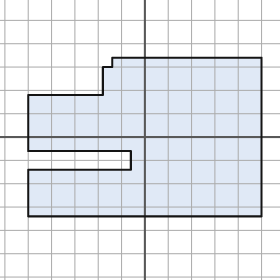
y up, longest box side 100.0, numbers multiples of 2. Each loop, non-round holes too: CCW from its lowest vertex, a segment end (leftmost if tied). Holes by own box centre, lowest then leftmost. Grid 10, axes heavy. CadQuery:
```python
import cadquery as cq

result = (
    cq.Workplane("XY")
    .moveTo(-50.0, -34.0)
    .lineTo(50.0, -34.0)
    .lineTo(50.0, 34.0)
    .lineTo(-14.0, 34.0)
    .lineTo(-14.0, 30.0)
    .lineTo(-18.0, 30.0)
    .lineTo(-18.0, 18.0)
    .lineTo(-50.0, 18.0)
    .lineTo(-50.0, -6.0)
    .lineTo(-6.0, -6.0)
    .lineTo(-6.0, -14.0)
    .lineTo(-50.0, -14.0)
    .close()
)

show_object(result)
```